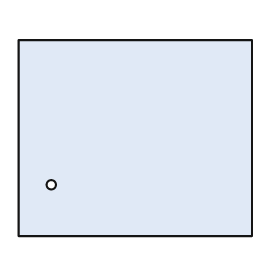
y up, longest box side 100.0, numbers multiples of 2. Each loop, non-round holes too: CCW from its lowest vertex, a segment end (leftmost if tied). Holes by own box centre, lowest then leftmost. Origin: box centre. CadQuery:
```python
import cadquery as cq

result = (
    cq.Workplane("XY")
    .moveTo(-50.0, -42.0)
    .lineTo(50.0, -42.0)
    .lineTo(50.0, 42.0)
    .lineTo(-50.0, 42.0)
    .close()
    .moveTo(-36.0, -20.0)
    .circle(2.0)
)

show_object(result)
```